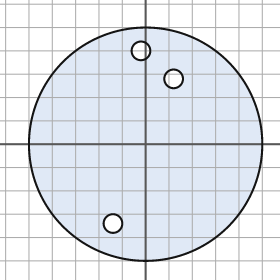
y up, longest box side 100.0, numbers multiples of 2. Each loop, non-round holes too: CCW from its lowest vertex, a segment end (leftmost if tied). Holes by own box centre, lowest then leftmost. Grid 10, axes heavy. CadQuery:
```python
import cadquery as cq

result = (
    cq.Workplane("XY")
    .moveTo(0.0, 0.0)
    .circle(50.0)
    .moveTo(-14.0, -34.0)
    .circle(4.0)
    .moveTo(12.0, 28.0)
    .circle(4.0)
    .moveTo(-2.0, 40.0)
    .circle(4.0)
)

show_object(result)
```